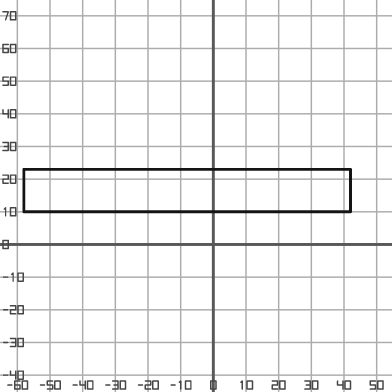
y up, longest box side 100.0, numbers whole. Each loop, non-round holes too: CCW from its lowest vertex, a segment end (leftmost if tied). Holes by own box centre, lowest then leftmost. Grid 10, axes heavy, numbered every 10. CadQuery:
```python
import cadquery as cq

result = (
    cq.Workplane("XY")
    .moveTo(-58.0, 10.0)
    .lineTo(42.0, 10.0)
    .lineTo(42.0, 23.0)
    .lineTo(-58.0, 23.0)
    .close()
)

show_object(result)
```